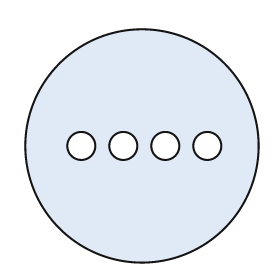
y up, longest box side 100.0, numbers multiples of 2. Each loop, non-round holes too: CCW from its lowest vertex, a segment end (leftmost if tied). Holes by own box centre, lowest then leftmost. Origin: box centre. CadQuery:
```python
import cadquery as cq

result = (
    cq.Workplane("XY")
    .moveTo(0.0, 0.0)
    .circle(50.0)
    .moveTo(-26.0, 0.0)
    .circle(6.0)
    .moveTo(-8.0, 0.0)
    .circle(6.0)
    .moveTo(10.0, 0.0)
    .circle(6.0)
    .moveTo(28.0, 0.0)
    .circle(6.0)
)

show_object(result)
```